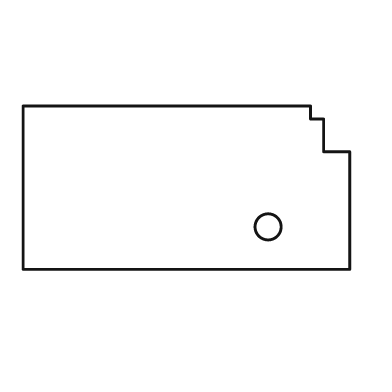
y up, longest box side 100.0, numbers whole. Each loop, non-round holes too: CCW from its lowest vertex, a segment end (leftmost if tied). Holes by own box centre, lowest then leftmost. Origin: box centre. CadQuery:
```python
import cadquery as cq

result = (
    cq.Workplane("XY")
    .moveTo(-50.0, -25.0)
    .lineTo(50.0, -25.0)
    .lineTo(50.0, 11.0)
    .lineTo(42.0, 11.0)
    .lineTo(42.0, 21.0)
    .lineTo(38.0, 21.0)
    .lineTo(38.0, 25.0)
    .lineTo(-50.0, 25.0)
    .close()
    .moveTo(25.0, -12.0)
    .circle(4.0)
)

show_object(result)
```